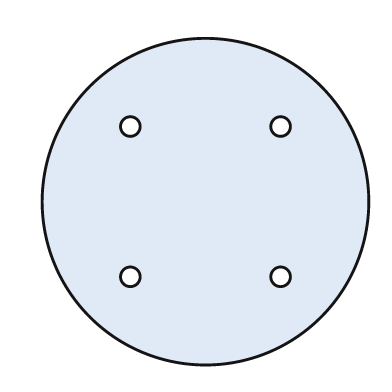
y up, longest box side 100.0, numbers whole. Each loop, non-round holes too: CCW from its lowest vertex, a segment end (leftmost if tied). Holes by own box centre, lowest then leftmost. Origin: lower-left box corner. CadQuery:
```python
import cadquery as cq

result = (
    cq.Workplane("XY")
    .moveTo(50.0, 50.0)
    .circle(50.0)
    .moveTo(27.0, 27.0)
    .circle(3.0)
    .moveTo(73.0, 27.0)
    .circle(3.0)
    .moveTo(27.0, 73.0)
    .circle(3.0)
    .moveTo(73.0, 73.0)
    .circle(3.0)
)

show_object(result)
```